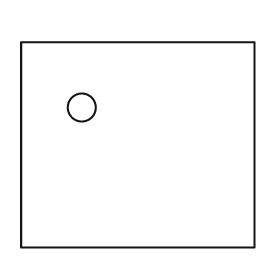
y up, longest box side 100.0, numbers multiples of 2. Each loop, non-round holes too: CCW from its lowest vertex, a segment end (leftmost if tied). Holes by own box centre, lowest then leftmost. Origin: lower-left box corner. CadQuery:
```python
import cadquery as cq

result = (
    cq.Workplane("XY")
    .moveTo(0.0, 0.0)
    .lineTo(100.0, 0.0)
    .lineTo(100.0, 88.0)
    .lineTo(0.0, 88.0)
    .close()
    .moveTo(26.0, 60.0)
    .circle(6.0)
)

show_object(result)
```